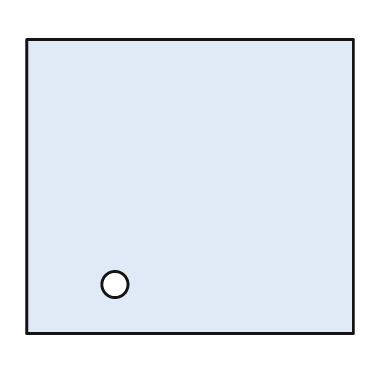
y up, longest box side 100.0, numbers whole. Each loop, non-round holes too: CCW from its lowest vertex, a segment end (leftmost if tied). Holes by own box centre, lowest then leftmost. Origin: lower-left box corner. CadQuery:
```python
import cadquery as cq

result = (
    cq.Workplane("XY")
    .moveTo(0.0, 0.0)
    .lineTo(100.0, 0.0)
    .lineTo(100.0, 90.0)
    .lineTo(0.0, 90.0)
    .close()
    .moveTo(27.0, 15.0)
    .circle(4.0)
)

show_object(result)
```